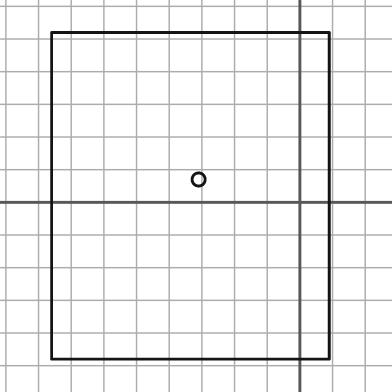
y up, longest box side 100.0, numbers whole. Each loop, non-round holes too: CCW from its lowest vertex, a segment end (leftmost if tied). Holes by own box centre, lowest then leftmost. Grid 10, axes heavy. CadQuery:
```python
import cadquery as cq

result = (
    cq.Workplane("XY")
    .moveTo(-76.0, -48.0)
    .lineTo(9.0, -48.0)
    .lineTo(9.0, 52.0)
    .lineTo(-76.0, 52.0)
    .close()
    .moveTo(-31.0, 7.0)
    .circle(2.0)
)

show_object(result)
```